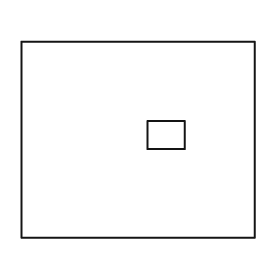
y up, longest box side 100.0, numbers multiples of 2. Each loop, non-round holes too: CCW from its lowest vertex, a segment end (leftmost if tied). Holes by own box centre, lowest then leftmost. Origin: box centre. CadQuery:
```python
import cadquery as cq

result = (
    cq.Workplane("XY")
    .moveTo(-50.0, -42.0)
    .lineTo(50.0, -42.0)
    .lineTo(50.0, 42.0)
    .lineTo(-50.0, 42.0)
    .close()
    .moveTo(4.0, -4.0)
    .lineTo(20.0, -4.0)
    .lineTo(20.0, 8.0)
    .lineTo(4.0, 8.0)
    .close()
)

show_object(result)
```